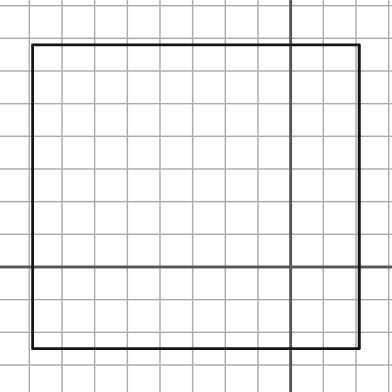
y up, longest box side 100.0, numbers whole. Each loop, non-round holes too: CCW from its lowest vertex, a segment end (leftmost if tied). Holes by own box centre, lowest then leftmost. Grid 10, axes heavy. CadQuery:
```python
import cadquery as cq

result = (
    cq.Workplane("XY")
    .moveTo(-79.0, -25.0)
    .lineTo(21.0, -25.0)
    .lineTo(21.0, 68.0)
    .lineTo(-79.0, 68.0)
    .close()
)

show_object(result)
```